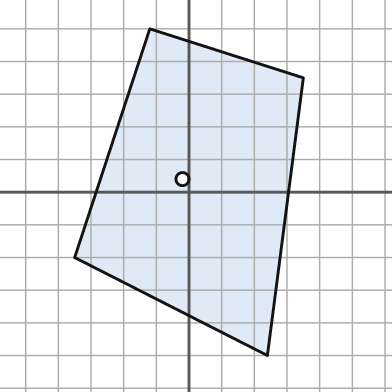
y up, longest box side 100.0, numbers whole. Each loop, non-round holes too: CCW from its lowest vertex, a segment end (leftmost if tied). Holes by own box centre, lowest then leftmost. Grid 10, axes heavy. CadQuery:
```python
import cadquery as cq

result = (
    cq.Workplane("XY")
    .moveTo(24.0, -50.0)
    .lineTo(35.0, 35.0)
    .lineTo(-12.0, 50.0)
    .lineTo(-35.0, -20.0)
    .close()
    .moveTo(-2.0, 4.0)
    .circle(2.0)
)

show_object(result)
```